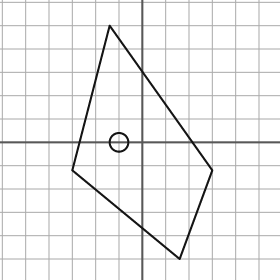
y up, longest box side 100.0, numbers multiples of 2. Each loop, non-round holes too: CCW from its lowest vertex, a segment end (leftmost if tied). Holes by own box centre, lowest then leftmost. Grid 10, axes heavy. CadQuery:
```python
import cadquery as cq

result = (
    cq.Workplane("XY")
    .moveTo(16.0, -50.0)
    .lineTo(30.0, -12.0)
    .lineTo(-14.0, 50.0)
    .lineTo(-30.0, -12.0)
    .close()
    .moveTo(-10.0, 0.0)
    .circle(4.0)
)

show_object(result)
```